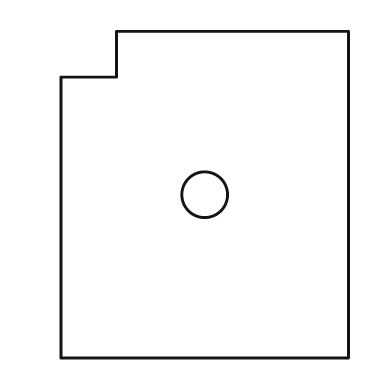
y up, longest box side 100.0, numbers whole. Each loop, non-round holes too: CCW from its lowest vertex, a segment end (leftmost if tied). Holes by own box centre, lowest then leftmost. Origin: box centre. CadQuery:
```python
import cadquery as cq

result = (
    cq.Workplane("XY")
    .moveTo(-44.0, -50.0)
    .lineTo(44.0, -50.0)
    .lineTo(44.0, 50.0)
    .lineTo(-27.0, 50.0)
    .lineTo(-27.0, 36.0)
    .lineTo(-44.0, 36.0)
    .close()
    .moveTo(0.0, 0.0)
    .circle(7.0)
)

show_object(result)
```